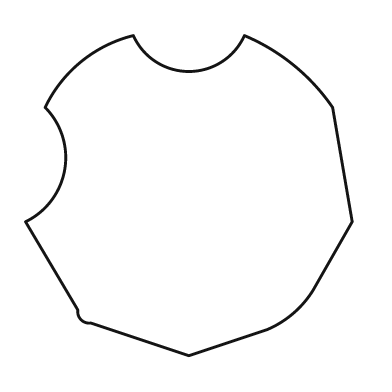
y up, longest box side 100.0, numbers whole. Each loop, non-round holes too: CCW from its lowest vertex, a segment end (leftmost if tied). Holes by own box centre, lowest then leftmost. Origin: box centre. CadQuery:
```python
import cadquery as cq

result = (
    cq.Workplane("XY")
    .moveTo(0.0, -49.0)
    .lineTo(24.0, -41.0)
    .threePointArc((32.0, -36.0), (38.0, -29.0))
    .lineTo(50.0, -8.0)
    .lineTo(44.0, 27.0)
    .threePointArc((32.0, 40.0), (17.0, 49.0))
    .threePointArc((0.0, 38.0), (-17.0, 49.0))
    .threePointArc((-33.0, 41.0), (-44.0, 27.0))
    .threePointArc((-38.0, 8.0), (-50.0, -8.0))
    .lineTo(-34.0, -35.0)
    .threePointArc((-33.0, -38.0), (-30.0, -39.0))
    .close()
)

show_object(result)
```